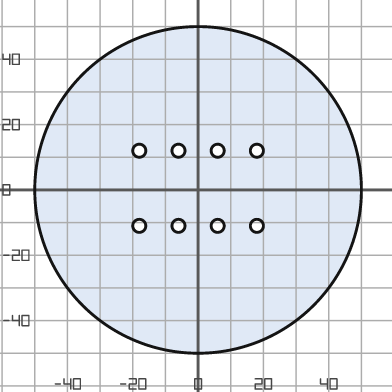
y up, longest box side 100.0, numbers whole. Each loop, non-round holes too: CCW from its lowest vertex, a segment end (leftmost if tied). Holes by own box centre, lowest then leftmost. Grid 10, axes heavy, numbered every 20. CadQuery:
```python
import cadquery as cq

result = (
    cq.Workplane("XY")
    .moveTo(0.0, 0.0)
    .circle(50.0)
    .moveTo(-18.0, -11.0)
    .circle(2.0)
    .moveTo(-6.0, -11.0)
    .circle(2.0)
    .moveTo(6.0, -11.0)
    .circle(2.0)
    .moveTo(18.0, -11.0)
    .circle(2.0)
    .moveTo(-18.0, 12.0)
    .circle(2.0)
    .moveTo(-6.0, 12.0)
    .circle(2.0)
    .moveTo(6.0, 12.0)
    .circle(2.0)
    .moveTo(18.0, 12.0)
    .circle(2.0)
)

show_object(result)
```